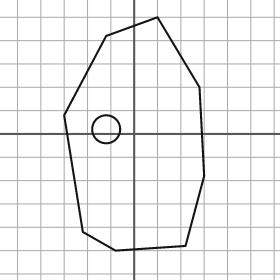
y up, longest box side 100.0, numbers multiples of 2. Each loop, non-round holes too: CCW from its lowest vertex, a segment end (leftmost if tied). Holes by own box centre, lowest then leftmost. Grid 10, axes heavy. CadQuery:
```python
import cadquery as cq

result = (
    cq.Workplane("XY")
    .moveTo(-8.0, -50.0)
    .lineTo(22.0, -48.0)
    .lineTo(30.0, -18.0)
    .lineTo(28.0, 20.0)
    .lineTo(10.0, 50.0)
    .lineTo(-12.0, 42.0)
    .lineTo(-30.0, 8.0)
    .lineTo(-22.0, -42.0)
    .close()
    .moveTo(-12.0, 2.0)
    .circle(6.0)
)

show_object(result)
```